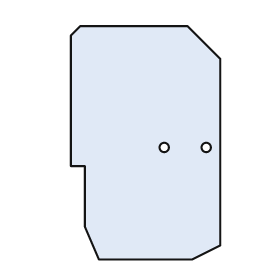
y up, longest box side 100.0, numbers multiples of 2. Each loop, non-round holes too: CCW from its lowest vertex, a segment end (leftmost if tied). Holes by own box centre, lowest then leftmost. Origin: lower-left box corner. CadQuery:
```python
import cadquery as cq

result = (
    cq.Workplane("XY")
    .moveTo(12.0, 0.0)
    .lineTo(52.0, 0.0)
    .lineTo(64.0, 6.0)
    .lineTo(64.0, 86.0)
    .lineTo(50.0, 100.0)
    .lineTo(4.0, 100.0)
    .lineTo(0.0, 96.0)
    .lineTo(0.0, 40.0)
    .lineTo(6.0, 40.0)
    .lineTo(6.0, 14.0)
    .close()
    .moveTo(40.0, 48.0)
    .circle(2.0)
    .moveTo(58.0, 48.0)
    .circle(2.0)
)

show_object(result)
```